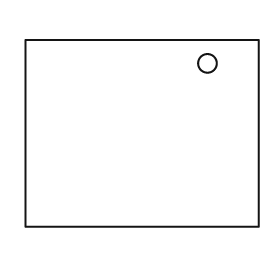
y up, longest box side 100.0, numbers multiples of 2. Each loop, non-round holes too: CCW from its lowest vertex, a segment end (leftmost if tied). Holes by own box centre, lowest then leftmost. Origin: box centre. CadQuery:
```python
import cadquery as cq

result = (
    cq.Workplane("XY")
    .moveTo(-50.0, -40.0)
    .lineTo(50.0, -40.0)
    .lineTo(50.0, 40.0)
    .lineTo(-50.0, 40.0)
    .close()
    .moveTo(28.0, 30.0)
    .circle(4.0)
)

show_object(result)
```